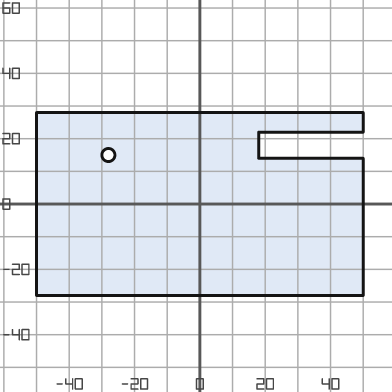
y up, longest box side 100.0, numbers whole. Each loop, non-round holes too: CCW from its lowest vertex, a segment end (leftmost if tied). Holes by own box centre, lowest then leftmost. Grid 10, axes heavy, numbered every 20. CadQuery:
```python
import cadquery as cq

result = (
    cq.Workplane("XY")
    .moveTo(-50.0, -28.0)
    .lineTo(50.0, -28.0)
    .lineTo(50.0, 14.0)
    .lineTo(18.0, 14.0)
    .lineTo(18.0, 22.0)
    .lineTo(50.0, 22.0)
    .lineTo(50.0, 28.0)
    .lineTo(-50.0, 28.0)
    .close()
    .moveTo(-28.0, 15.0)
    .circle(2.0)
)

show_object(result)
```